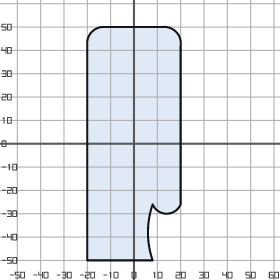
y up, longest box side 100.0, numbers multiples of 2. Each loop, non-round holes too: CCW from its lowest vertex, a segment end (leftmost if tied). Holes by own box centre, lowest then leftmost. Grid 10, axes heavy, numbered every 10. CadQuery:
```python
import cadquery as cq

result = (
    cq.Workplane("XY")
    .moveTo(-20.0, -50.0)
    .lineTo(8.0, -50.0)
    .threePointArc((6.0, -38.0), (8.0, -26.0))
    .threePointArc((14.0, -30.0), (20.0, -26.0))
    .lineTo(20.0, 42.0)
    .threePointArc((18.0, 48.0), (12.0, 50.0))
    .lineTo(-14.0, 50.0)
    .threePointArc((-18.0, 48.0), (-20.0, 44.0))
    .close()
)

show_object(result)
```